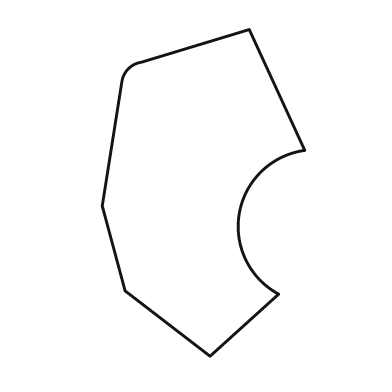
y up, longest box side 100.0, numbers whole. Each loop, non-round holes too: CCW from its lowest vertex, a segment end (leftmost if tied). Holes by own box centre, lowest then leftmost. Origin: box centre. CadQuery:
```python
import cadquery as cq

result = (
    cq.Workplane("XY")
    .moveTo(2.0, -50.0)
    .lineTo(23.0, -31.0)
    .threePointArc((11.0, -6.0), (31.0, 13.0))
    .lineTo(14.0, 50.0)
    .lineTo(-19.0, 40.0)
    .threePointArc((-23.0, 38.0), (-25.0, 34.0))
    .lineTo(-31.0, -4.0)
    .lineTo(-24.0, -30.0)
    .close()
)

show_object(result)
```